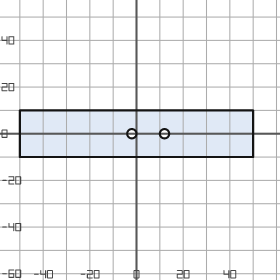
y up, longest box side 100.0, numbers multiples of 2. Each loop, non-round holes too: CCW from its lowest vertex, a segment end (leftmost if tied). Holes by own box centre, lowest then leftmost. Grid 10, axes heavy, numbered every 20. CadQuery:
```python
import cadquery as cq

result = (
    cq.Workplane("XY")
    .moveTo(-50.0, -10.0)
    .lineTo(50.0, -10.0)
    .lineTo(50.0, 10.0)
    .lineTo(-50.0, 10.0)
    .close()
    .moveTo(-2.0, 0.0)
    .circle(2.0)
    .moveTo(12.0, 0.0)
    .circle(2.0)
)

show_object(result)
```